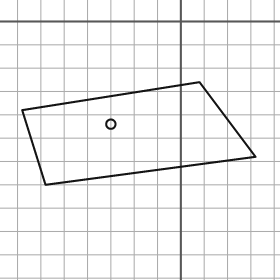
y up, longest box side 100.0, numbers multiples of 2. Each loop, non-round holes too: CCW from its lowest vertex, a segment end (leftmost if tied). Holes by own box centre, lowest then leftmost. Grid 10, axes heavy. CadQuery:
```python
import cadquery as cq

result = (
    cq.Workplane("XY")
    .moveTo(-58.0, -70.0)
    .lineTo(32.0, -58.0)
    .lineTo(8.0, -26.0)
    .lineTo(-68.0, -38.0)
    .close()
    .moveTo(-30.0, -44.0)
    .circle(2.0)
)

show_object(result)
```